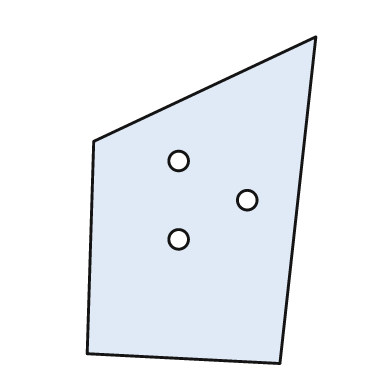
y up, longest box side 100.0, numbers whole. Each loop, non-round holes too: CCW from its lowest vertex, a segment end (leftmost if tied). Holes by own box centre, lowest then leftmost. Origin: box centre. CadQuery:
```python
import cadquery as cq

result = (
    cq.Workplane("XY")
    .moveTo(24.0, -50.0)
    .lineTo(35.0, 50.0)
    .lineTo(-33.0, 18.0)
    .lineTo(-35.0, -47.0)
    .close()
    .moveTo(-7.0, -12.0)
    .circle(3.0)
    .moveTo(14.0, 0.0)
    .circle(3.0)
    .moveTo(-7.0, 12.0)
    .circle(3.0)
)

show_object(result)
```